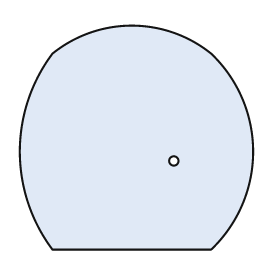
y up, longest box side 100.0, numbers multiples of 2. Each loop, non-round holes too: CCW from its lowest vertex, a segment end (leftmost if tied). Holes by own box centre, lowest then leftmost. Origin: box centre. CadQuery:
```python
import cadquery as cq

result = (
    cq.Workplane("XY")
    .moveTo(-36.0, -48.0)
    .lineTo(32.0, -48.0)
    .threePointArc((50.0, -6.0), (32.0, 36.0))
    .threePointArc((-2.0, 48.0), (-36.0, 36.0))
    .threePointArc((-50.0, -6.0), (-36.0, -48.0))
    .close()
    .moveTo(16.0, -10.0)
    .circle(2.0)
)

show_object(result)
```